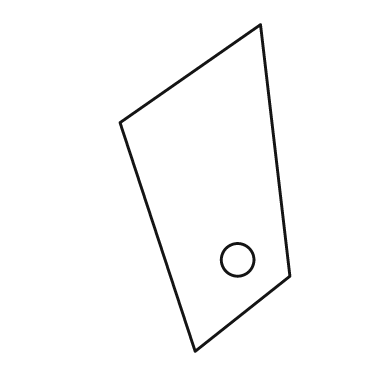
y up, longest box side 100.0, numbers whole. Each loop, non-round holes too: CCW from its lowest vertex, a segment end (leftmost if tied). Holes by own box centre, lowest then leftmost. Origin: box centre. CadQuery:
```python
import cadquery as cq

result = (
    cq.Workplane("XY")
    .moveTo(-3.0, -50.0)
    .lineTo(26.0, -27.0)
    .lineTo(17.0, 50.0)
    .lineTo(-26.0, 20.0)
    .close()
    .moveTo(10.0, -22.0)
    .circle(5.0)
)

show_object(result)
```